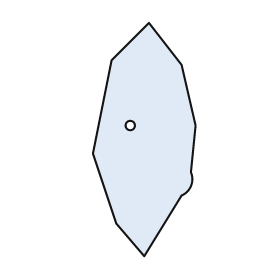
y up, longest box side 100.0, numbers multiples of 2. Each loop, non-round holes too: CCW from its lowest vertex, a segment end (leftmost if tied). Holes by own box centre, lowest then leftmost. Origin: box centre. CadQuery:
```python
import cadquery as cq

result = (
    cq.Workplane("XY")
    .moveTo(0.0, -50.0)
    .lineTo(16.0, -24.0)
    .threePointArc((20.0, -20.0), (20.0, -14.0))
    .lineTo(22.0, 6.0)
    .lineTo(16.0, 32.0)
    .lineTo(2.0, 50.0)
    .lineTo(-14.0, 34.0)
    .lineTo(-22.0, -6.0)
    .lineTo(-12.0, -36.0)
    .close()
    .moveTo(-6.0, 6.0)
    .circle(2.0)
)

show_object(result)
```